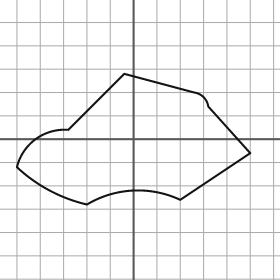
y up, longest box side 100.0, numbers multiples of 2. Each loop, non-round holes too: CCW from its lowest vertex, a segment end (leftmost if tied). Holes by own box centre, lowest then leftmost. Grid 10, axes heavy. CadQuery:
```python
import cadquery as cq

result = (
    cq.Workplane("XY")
    .moveTo(-20.0, -28.0)
    .threePointArc((0.0, -22.0), (20.0, -26.0))
    .lineTo(50.0, -6.0)
    .lineTo(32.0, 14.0)
    .threePointArc((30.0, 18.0), (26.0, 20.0))
    .lineTo(-4.0, 28.0)
    .lineTo(-28.0, 4.0)
    .threePointArc((-42.0, 0.0), (-50.0, -12.0))
    .threePointArc((-36.0, -22.0), (-20.0, -28.0))
    .close()
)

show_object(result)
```